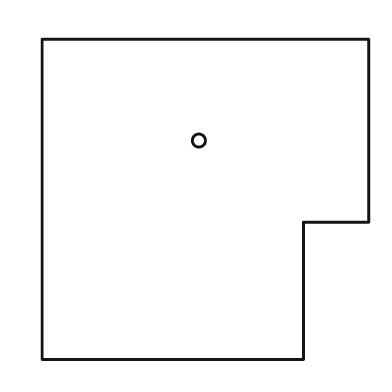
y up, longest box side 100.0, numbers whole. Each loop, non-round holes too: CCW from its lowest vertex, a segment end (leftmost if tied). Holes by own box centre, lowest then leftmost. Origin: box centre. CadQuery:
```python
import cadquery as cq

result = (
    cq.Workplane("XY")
    .moveTo(-50.0, -49.0)
    .lineTo(30.0, -49.0)
    .lineTo(30.0, -7.0)
    .lineTo(50.0, -7.0)
    .lineTo(50.0, 49.0)
    .lineTo(-50.0, 49.0)
    .close()
    .moveTo(-2.0, 18.0)
    .circle(2.0)
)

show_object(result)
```